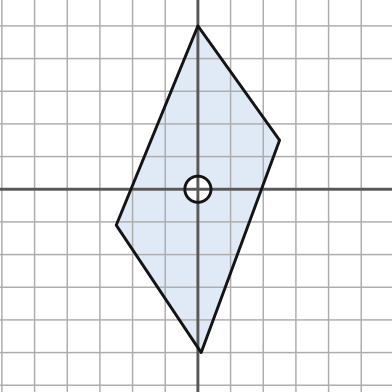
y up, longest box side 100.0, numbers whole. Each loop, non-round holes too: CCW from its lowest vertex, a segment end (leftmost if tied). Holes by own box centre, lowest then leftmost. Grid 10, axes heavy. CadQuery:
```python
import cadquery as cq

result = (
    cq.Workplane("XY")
    .moveTo(1.0, -50.0)
    .lineTo(25.0, 15.0)
    .lineTo(0.0, 50.0)
    .lineTo(-25.0, -11.0)
    .close()
    .moveTo(0.0, 0.0)
    .circle(4.0)
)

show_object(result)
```